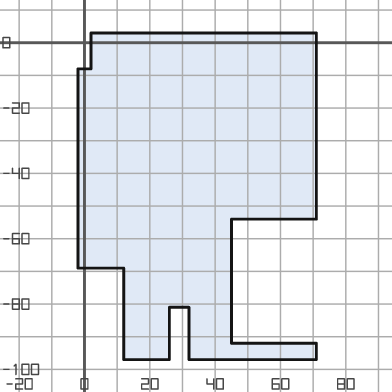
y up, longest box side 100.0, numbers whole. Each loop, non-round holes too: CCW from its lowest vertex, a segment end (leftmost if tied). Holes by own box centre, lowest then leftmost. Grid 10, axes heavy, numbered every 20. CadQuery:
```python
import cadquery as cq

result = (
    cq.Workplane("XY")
    .moveTo(12.0, -97.0)
    .lineTo(26.0, -97.0)
    .lineTo(26.0, -81.0)
    .lineTo(32.0, -81.0)
    .lineTo(32.0, -97.0)
    .lineTo(71.0, -97.0)
    .lineTo(71.0, -92.0)
    .lineTo(45.0, -92.0)
    .lineTo(45.0, -54.0)
    .lineTo(71.0, -54.0)
    .lineTo(71.0, 3.0)
    .lineTo(2.0, 3.0)
    .lineTo(2.0, -8.0)
    .lineTo(-2.0, -8.0)
    .lineTo(-2.0, -69.0)
    .lineTo(12.0, -69.0)
    .close()
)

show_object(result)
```